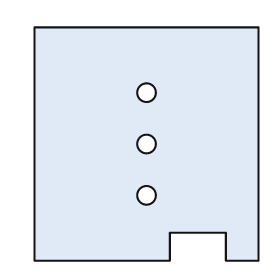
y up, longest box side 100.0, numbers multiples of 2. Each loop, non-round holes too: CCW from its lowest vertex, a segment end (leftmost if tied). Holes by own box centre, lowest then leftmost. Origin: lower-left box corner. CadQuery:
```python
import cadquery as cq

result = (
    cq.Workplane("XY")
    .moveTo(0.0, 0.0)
    .lineTo(58.0, 0.0)
    .lineTo(58.0, 12.0)
    .lineTo(82.0, 12.0)
    .lineTo(82.0, 0.0)
    .lineTo(96.0, 0.0)
    .lineTo(96.0, 100.0)
    .lineTo(0.0, 100.0)
    .close()
    .moveTo(48.0, 28.0)
    .circle(4.0)
    .moveTo(48.0, 50.0)
    .circle(4.0)
    .moveTo(48.0, 72.0)
    .circle(4.0)
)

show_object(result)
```